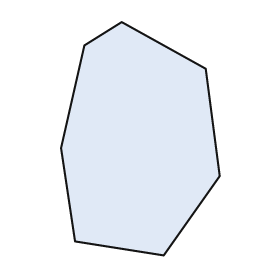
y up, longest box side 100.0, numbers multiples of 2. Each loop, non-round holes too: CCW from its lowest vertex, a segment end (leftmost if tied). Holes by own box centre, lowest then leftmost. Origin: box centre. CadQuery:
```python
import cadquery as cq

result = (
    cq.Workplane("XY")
    .moveTo(10.0, -50.0)
    .lineTo(34.0, -16.0)
    .lineTo(28.0, 30.0)
    .lineTo(-8.0, 50.0)
    .lineTo(-24.0, 40.0)
    .lineTo(-34.0, -4.0)
    .lineTo(-28.0, -44.0)
    .close()
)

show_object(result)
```